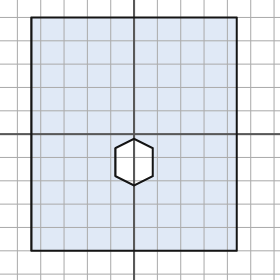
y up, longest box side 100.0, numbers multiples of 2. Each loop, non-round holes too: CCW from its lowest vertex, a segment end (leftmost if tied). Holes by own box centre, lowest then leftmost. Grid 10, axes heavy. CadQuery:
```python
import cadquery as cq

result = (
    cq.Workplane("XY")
    .moveTo(-44.0, -50.0)
    .lineTo(44.0, -50.0)
    .lineTo(44.0, 50.0)
    .lineTo(-44.0, 50.0)
    .close()
    .moveTo(0.0, -22.0)
    .lineTo(8.0, -18.0)
    .lineTo(8.0, -6.0)
    .lineTo(0.0, -2.0)
    .lineTo(-8.0, -6.0)
    .lineTo(-8.0, -18.0)
    .close()
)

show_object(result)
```